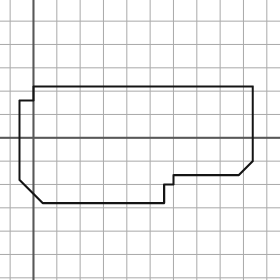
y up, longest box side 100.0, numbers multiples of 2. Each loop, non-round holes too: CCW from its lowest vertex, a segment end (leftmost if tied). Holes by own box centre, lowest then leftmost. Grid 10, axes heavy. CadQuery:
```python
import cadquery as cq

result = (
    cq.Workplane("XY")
    .moveTo(4.0, -28.0)
    .lineTo(56.0, -28.0)
    .lineTo(56.0, -20.0)
    .lineTo(60.0, -20.0)
    .lineTo(60.0, -16.0)
    .lineTo(88.0, -16.0)
    .lineTo(94.0, -10.0)
    .lineTo(94.0, 22.0)
    .lineTo(0.0, 22.0)
    .lineTo(0.0, 16.0)
    .lineTo(-6.0, 16.0)
    .lineTo(-6.0, -18.0)
    .close()
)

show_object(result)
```